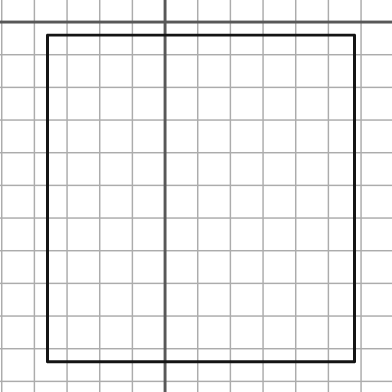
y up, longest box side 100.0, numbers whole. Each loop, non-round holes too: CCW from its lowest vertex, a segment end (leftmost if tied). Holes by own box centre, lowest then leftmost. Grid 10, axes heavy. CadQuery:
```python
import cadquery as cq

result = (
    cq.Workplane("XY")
    .moveTo(-36.0, -104.0)
    .lineTo(58.0, -104.0)
    .lineTo(58.0, -4.0)
    .lineTo(-36.0, -4.0)
    .close()
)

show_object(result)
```